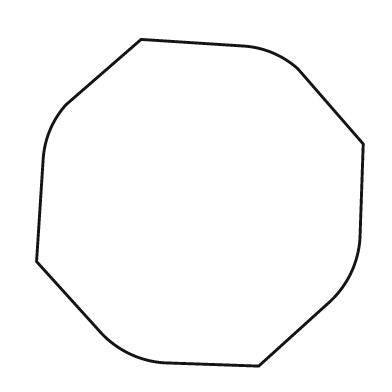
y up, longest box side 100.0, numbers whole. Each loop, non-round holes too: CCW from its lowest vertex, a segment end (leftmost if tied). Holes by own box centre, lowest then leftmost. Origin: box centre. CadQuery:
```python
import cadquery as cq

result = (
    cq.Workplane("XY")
    .moveTo(18.0, -50.0)
    .lineTo(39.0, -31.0)
    .threePointArc((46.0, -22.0), (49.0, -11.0))
    .lineTo(50.0, 18.0)
    .lineTo(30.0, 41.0)
    .threePointArc((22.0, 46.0), (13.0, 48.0))
    .lineTo(-18.0, 50.0)
    .lineTo(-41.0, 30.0)
    .threePointArc((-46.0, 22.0), (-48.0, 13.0))
    .lineTo(-50.0, -18.0)
    .lineTo(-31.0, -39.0)
    .threePointArc((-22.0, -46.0), (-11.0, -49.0))
    .close()
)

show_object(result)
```